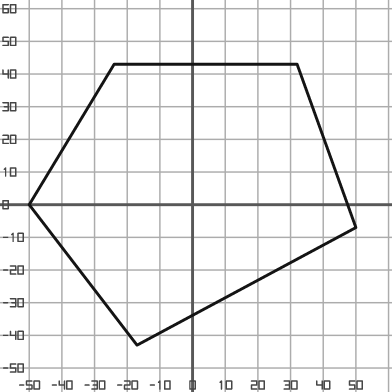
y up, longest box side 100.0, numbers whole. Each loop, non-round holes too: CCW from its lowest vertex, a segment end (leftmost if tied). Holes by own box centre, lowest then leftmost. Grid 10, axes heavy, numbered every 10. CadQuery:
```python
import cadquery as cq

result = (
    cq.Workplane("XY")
    .moveTo(-17.0, -43.0)
    .lineTo(50.0, -7.0)
    .lineTo(32.0, 43.0)
    .lineTo(-24.0, 43.0)
    .lineTo(-50.0, 0.0)
    .close()
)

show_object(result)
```